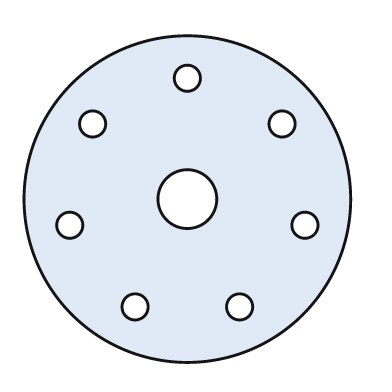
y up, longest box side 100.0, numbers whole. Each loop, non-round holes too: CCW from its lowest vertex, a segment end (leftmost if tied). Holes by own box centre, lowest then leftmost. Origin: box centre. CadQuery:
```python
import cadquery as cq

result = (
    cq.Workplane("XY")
    .moveTo(0.0, 0.0)
    .circle(50.0)
    .moveTo(-16.0, -33.0)
    .circle(4.0)
    .moveTo(16.0, -33.0)
    .circle(4.0)
    .moveTo(-36.0, -8.0)
    .circle(4.0)
    .moveTo(36.0, -8.0)
    .circle(4.0)
    .moveTo(0.0, 0.0)
    .circle(9.0)
    .moveTo(-29.0, 23.0)
    .circle(4.0)
    .moveTo(29.0, 23.0)
    .circle(4.0)
    .moveTo(0.0, 37.0)
    .circle(4.0)
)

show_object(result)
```